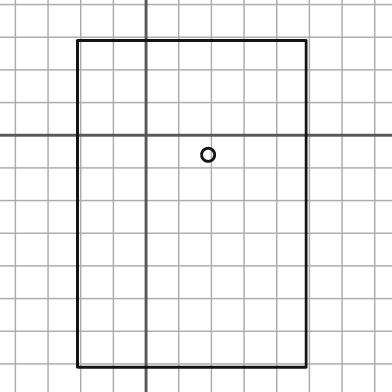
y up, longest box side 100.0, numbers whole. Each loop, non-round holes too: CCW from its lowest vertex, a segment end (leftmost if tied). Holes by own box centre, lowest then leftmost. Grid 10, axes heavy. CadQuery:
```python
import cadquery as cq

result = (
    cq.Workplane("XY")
    .moveTo(-21.0, -71.0)
    .lineTo(49.0, -71.0)
    .lineTo(49.0, 29.0)
    .lineTo(-21.0, 29.0)
    .close()
    .moveTo(19.0, -6.0)
    .circle(2.0)
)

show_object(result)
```